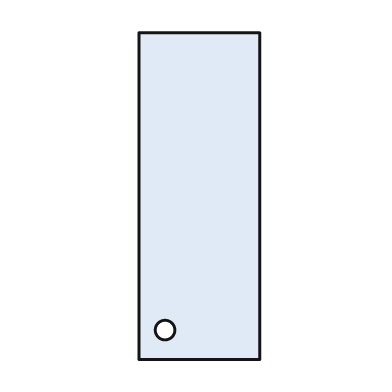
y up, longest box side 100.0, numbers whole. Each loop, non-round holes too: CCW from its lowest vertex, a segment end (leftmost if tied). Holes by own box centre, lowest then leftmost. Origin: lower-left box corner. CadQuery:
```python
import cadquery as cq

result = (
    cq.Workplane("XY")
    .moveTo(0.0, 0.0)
    .lineTo(37.0, 0.0)
    .lineTo(37.0, 100.0)
    .lineTo(0.0, 100.0)
    .close()
    .moveTo(8.0, 9.0)
    .circle(3.0)
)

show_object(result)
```